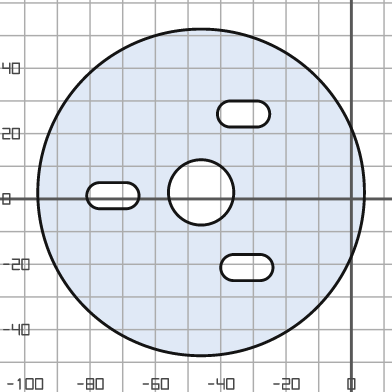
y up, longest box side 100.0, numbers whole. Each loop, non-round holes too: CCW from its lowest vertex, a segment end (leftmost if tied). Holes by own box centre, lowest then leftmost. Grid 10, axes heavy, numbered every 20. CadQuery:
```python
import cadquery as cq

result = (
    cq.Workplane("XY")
    .moveTo(-46.0, 2.0)
    .circle(50.0)
    .moveTo(-36.0, -25.0)
    .lineTo(-28.0, -25.0)
    .threePointArc((-24.0, -21.0), (-28.0, -17.0))
    .lineTo(-36.0, -17.0)
    .threePointArc((-40.0, -21.0), (-36.0, -25.0))
    .close()
    .moveTo(-77.0, -3.0)
    .lineTo(-69.0, -3.0)
    .threePointArc((-65.0, 1.0), (-69.0, 5.0))
    .lineTo(-77.0, 5.0)
    .threePointArc((-81.0, 1.0), (-77.0, -3.0))
    .close()
    .moveTo(-46.0, 2.0)
    .circle(10.0)
    .moveTo(-37.0, 22.0)
    .lineTo(-29.0, 22.0)
    .threePointArc((-25.0, 26.0), (-29.0, 30.0))
    .lineTo(-37.0, 30.0)
    .threePointArc((-41.0, 26.0), (-37.0, 22.0))
    .close()
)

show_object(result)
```